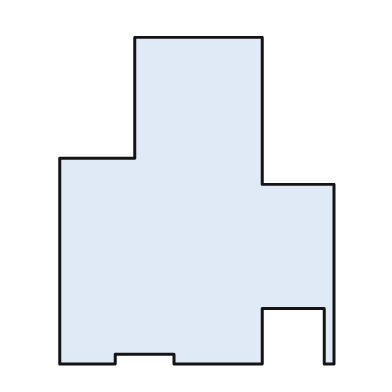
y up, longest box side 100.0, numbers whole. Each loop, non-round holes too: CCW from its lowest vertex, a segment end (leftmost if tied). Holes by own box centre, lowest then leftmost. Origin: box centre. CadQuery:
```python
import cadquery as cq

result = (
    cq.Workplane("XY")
    .moveTo(-42.0, -50.0)
    .lineTo(-25.0, -50.0)
    .lineTo(-25.0, -47.0)
    .lineTo(-7.0, -47.0)
    .lineTo(-7.0, -50.0)
    .lineTo(20.0, -50.0)
    .lineTo(20.0, -33.0)
    .lineTo(39.0, -33.0)
    .lineTo(39.0, -50.0)
    .lineTo(42.0, -50.0)
    .lineTo(42.0, 5.0)
    .lineTo(20.0, 5.0)
    .lineTo(20.0, 50.0)
    .lineTo(-19.0, 50.0)
    .lineTo(-19.0, 13.0)
    .lineTo(-42.0, 13.0)
    .close()
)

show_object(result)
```